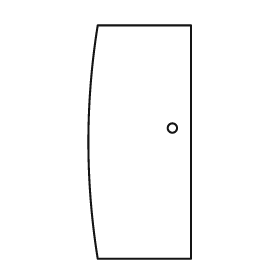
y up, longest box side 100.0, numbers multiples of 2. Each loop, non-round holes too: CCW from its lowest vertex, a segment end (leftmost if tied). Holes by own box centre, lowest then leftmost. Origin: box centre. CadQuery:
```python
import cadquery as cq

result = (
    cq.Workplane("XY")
    .moveTo(-18.0, -50.0)
    .lineTo(22.0, -50.0)
    .lineTo(22.0, 50.0)
    .lineTo(-18.0, 50.0)
    .threePointArc((-22.0, 0.0), (-18.0, -50.0))
    .close()
    .moveTo(14.0, 6.0)
    .circle(2.0)
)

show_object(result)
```